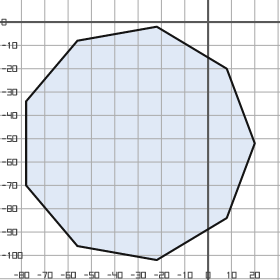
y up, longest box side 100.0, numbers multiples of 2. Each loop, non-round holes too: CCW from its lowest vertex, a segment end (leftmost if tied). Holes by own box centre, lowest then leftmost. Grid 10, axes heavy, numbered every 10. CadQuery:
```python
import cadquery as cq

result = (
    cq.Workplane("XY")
    .moveTo(-22.0, -102.0)
    .lineTo(8.0, -84.0)
    .lineTo(20.0, -52.0)
    .lineTo(8.0, -20.0)
    .lineTo(-22.0, -2.0)
    .lineTo(-56.0, -8.0)
    .lineTo(-78.0, -34.0)
    .lineTo(-78.0, -70.0)
    .lineTo(-56.0, -96.0)
    .close()
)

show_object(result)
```